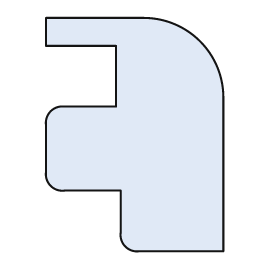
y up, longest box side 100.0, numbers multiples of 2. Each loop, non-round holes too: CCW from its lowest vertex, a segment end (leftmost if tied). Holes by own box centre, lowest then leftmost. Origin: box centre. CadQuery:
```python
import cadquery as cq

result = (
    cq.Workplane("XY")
    .moveTo(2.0, -50.0)
    .lineTo(38.0, -50.0)
    .lineTo(38.0, 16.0)
    .threePointArc((28.0, 40.0), (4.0, 50.0))
    .lineTo(-38.0, 50.0)
    .lineTo(-38.0, 38.0)
    .lineTo(-8.0, 38.0)
    .lineTo(-8.0, 12.0)
    .lineTo(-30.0, 12.0)
    .threePointArc((-36.0, 10.0), (-38.0, 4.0))
    .lineTo(-38.0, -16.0)
    .threePointArc((-36.0, -22.0), (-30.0, -24.0))
    .lineTo(-6.0, -24.0)
    .lineTo(-6.0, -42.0)
    .threePointArc((-4.0, -48.0), (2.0, -50.0))
    .close()
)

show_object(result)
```